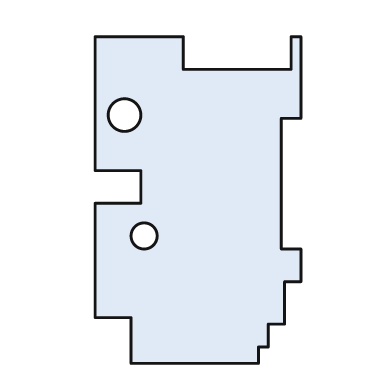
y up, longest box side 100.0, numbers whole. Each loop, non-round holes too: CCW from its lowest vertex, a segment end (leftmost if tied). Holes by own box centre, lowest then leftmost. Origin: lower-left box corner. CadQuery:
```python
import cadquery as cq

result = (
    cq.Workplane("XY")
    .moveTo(11.0, 0.0)
    .lineTo(50.0, 0.0)
    .lineTo(50.0, 5.0)
    .lineTo(53.0, 5.0)
    .lineTo(53.0, 12.0)
    .lineTo(58.0, 12.0)
    .lineTo(58.0, 25.0)
    .lineTo(63.0, 25.0)
    .lineTo(63.0, 35.0)
    .lineTo(57.0, 35.0)
    .lineTo(57.0, 75.0)
    .lineTo(63.0, 75.0)
    .lineTo(63.0, 100.0)
    .lineTo(60.0, 100.0)
    .lineTo(60.0, 90.0)
    .lineTo(27.0, 90.0)
    .lineTo(27.0, 100.0)
    .lineTo(0.0, 100.0)
    .lineTo(0.0, 59.0)
    .lineTo(14.0, 59.0)
    .lineTo(14.0, 49.0)
    .lineTo(0.0, 49.0)
    .lineTo(0.0, 14.0)
    .lineTo(11.0, 14.0)
    .close()
    .moveTo(15.0, 39.0)
    .circle(4.0)
    .moveTo(9.0, 76.0)
    .circle(5.0)
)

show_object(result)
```